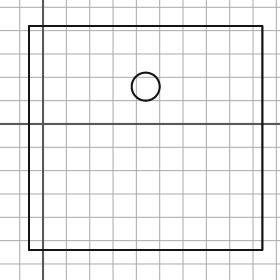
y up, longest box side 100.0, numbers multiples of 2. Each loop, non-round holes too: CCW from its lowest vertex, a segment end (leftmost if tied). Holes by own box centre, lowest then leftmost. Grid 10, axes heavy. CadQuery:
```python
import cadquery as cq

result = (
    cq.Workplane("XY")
    .moveTo(-6.0, -54.0)
    .lineTo(94.0, -54.0)
    .lineTo(94.0, 42.0)
    .lineTo(-6.0, 42.0)
    .close()
    .moveTo(44.0, 16.0)
    .circle(6.0)
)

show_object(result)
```